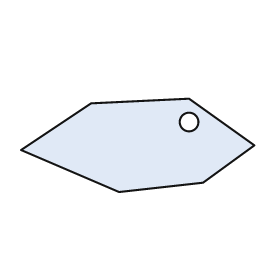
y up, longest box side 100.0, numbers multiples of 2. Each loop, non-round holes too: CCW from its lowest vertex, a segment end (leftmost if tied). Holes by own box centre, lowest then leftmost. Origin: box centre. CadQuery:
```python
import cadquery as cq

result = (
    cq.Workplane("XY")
    .moveTo(-8.0, -20.0)
    .lineTo(28.0, -16.0)
    .lineTo(50.0, 0.0)
    .lineTo(22.0, 20.0)
    .lineTo(-20.0, 18.0)
    .lineTo(-50.0, -2.0)
    .close()
    .moveTo(22.0, 10.0)
    .circle(4.0)
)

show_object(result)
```